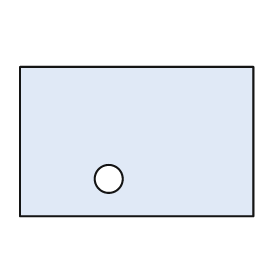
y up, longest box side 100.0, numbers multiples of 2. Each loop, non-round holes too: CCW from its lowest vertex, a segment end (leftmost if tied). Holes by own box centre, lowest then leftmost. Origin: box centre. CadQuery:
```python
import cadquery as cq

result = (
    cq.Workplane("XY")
    .moveTo(-50.0, -32.0)
    .lineTo(50.0, -32.0)
    .lineTo(50.0, 32.0)
    .lineTo(-50.0, 32.0)
    .close()
    .moveTo(-12.0, -16.0)
    .circle(6.0)
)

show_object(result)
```